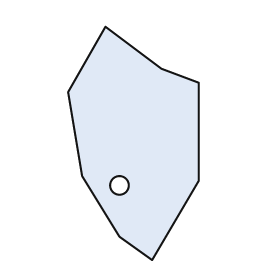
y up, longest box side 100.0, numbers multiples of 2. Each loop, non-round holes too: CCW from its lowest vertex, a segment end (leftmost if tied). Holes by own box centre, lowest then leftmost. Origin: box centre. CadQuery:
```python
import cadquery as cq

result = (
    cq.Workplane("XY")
    .moveTo(8.0, -50.0)
    .lineTo(28.0, -16.0)
    .lineTo(28.0, 26.0)
    .lineTo(12.0, 32.0)
    .lineTo(-12.0, 50.0)
    .lineTo(-28.0, 22.0)
    .lineTo(-22.0, -14.0)
    .lineTo(-6.0, -40.0)
    .close()
    .moveTo(-6.0, -18.0)
    .circle(4.0)
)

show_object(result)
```